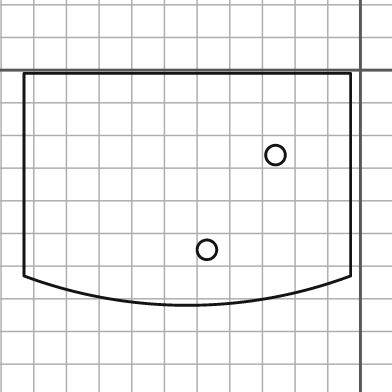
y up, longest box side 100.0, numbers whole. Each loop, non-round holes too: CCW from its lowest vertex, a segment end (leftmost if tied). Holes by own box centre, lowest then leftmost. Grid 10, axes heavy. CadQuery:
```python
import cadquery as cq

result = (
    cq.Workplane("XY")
    .moveTo(-103.0, -63.0)
    .threePointArc((-53.0, -72.0), (-3.0, -63.0))
    .lineTo(-3.0, -1.0)
    .lineTo(-103.0, -1.0)
    .close()
    .moveTo(-47.0, -55.0)
    .circle(3.0)
    .moveTo(-26.0, -26.0)
    .circle(3.0)
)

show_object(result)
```